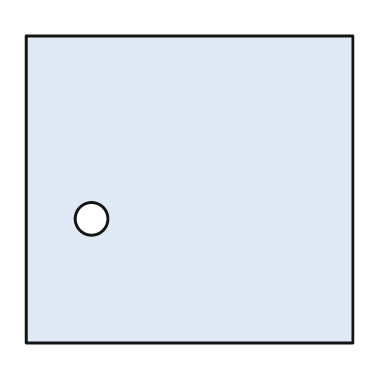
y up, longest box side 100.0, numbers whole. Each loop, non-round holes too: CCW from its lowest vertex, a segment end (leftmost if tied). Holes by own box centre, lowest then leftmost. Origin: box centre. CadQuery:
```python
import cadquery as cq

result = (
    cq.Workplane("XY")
    .moveTo(-50.0, -47.0)
    .lineTo(50.0, -47.0)
    .lineTo(50.0, 47.0)
    .lineTo(-50.0, 47.0)
    .close()
    .moveTo(-30.0, -9.0)
    .circle(5.0)
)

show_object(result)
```